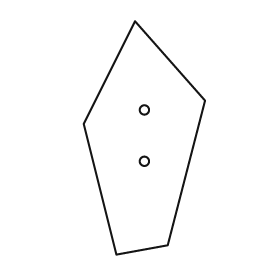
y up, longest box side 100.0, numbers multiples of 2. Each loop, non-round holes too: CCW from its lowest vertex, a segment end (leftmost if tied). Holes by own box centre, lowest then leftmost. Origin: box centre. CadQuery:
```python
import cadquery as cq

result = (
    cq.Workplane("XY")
    .moveTo(-12.0, -50.0)
    .lineTo(10.0, -46.0)
    .lineTo(26.0, 16.0)
    .lineTo(-4.0, 50.0)
    .lineTo(-26.0, 6.0)
    .close()
    .moveTo(0.0, -10.0)
    .circle(2.0)
    .moveTo(0.0, 12.0)
    .circle(2.0)
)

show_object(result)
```